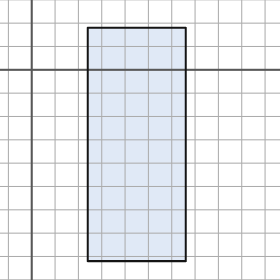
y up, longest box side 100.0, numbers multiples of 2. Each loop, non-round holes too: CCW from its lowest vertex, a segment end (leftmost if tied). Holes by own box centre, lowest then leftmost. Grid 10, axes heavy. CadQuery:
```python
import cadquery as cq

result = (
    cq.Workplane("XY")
    .moveTo(24.0, -82.0)
    .lineTo(66.0, -82.0)
    .lineTo(66.0, 18.0)
    .lineTo(24.0, 18.0)
    .close()
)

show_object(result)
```